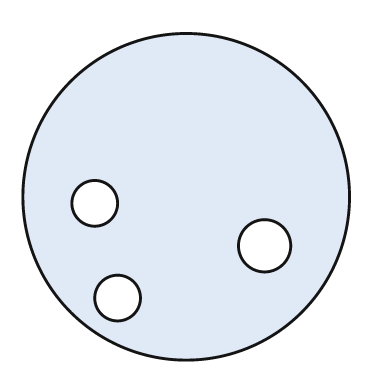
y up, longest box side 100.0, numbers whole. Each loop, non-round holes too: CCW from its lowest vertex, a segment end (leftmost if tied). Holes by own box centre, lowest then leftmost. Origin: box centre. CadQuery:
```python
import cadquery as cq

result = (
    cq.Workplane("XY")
    .moveTo(0.0, 0.0)
    .circle(50.0)
    .moveTo(-21.0, -31.0)
    .circle(7.0)
    .moveTo(24.0, -15.0)
    .circle(8.0)
    .moveTo(-28.0, -2.0)
    .circle(7.0)
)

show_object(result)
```